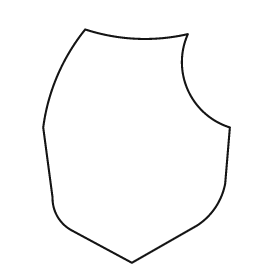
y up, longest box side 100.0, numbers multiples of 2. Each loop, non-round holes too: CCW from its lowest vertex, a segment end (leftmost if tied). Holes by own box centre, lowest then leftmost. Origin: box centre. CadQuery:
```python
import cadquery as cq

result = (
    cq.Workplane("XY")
    .moveTo(-2.0, -50.0)
    .lineTo(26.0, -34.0)
    .threePointArc((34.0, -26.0), (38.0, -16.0))
    .lineTo(40.0, 8.0)
    .threePointArc((22.0, 24.0), (22.0, 48.0))
    .threePointArc((0.0, 46.0), (-22.0, 50.0))
    .threePointArc((-34.0, 30.0), (-40.0, 8.0))
    .lineTo(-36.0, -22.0)
    .threePointArc((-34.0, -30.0), (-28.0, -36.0))
    .close()
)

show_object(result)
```